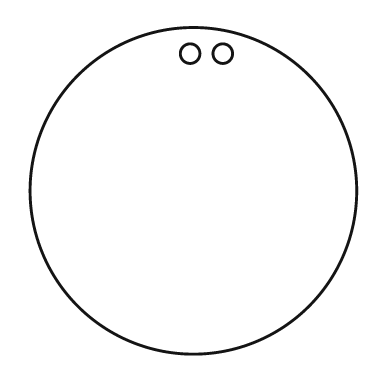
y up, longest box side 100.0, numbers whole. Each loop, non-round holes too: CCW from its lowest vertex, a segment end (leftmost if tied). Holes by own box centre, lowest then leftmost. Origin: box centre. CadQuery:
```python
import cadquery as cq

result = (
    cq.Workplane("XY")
    .moveTo(0.0, 0.0)
    .circle(50.0)
    .moveTo(-1.0, 42.0)
    .circle(3.0)
    .moveTo(9.0, 42.0)
    .circle(3.0)
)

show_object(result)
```